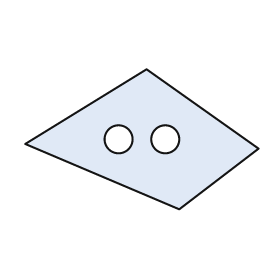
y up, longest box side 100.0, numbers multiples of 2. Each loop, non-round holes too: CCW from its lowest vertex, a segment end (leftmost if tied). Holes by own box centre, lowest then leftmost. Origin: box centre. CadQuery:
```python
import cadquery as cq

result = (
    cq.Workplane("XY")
    .moveTo(16.0, -30.0)
    .lineTo(50.0, -4.0)
    .lineTo(2.0, 30.0)
    .lineTo(-50.0, -2.0)
    .close()
    .moveTo(-10.0, 0.0)
    .circle(6.0)
    .moveTo(10.0, 0.0)
    .circle(6.0)
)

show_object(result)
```